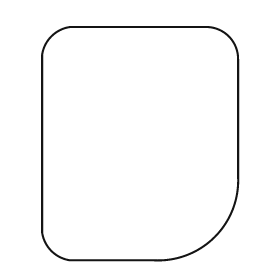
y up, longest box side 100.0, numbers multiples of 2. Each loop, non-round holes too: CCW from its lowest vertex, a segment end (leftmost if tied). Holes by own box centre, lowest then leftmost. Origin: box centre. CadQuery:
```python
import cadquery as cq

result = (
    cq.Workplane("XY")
    .moveTo(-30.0, -50.0)
    .lineTo(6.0, -50.0)
    .threePointArc((32.0, -40.0), (42.0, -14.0))
    .lineTo(42.0, 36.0)
    .threePointArc((38.0, 46.0), (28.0, 50.0))
    .lineTo(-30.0, 50.0)
    .threePointArc((-38.0, 46.0), (-42.0, 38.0))
    .lineTo(-42.0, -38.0)
    .threePointArc((-38.0, -46.0), (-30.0, -50.0))
    .close()
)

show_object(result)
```